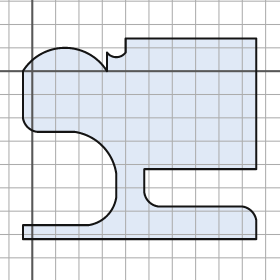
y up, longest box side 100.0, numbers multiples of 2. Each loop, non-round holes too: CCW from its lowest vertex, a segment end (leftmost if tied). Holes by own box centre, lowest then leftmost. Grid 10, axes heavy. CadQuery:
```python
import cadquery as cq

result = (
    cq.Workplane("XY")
    .moveTo(-4.0, -72.0)
    .lineTo(96.0, -72.0)
    .lineTo(96.0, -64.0)
    .threePointArc((94.0, -60.0), (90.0, -58.0))
    .lineTo(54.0, -58.0)
    .threePointArc((50.0, -56.0), (48.0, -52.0))
    .lineTo(48.0, -42.0)
    .lineTo(96.0, -42.0)
    .lineTo(96.0, 14.0)
    .lineTo(40.0, 14.0)
    .lineTo(40.0, 8.0)
    .threePointArc((36.0, 6.0), (32.0, 8.0))
    .lineTo(32.0, 0.0)
    .threePointArc((14.0, 10.0), (-4.0, 0.0))
    .lineTo(-4.0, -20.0)
    .threePointArc((-2.0, -24.0), (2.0, -26.0))
    .lineTo(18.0, -26.0)
    .threePointArc((30.0, -32.0), (36.0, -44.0))
    .lineTo(36.0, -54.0)
    .threePointArc((32.0, -62.0), (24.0, -66.0))
    .lineTo(-4.0, -66.0)
    .close()
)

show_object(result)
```